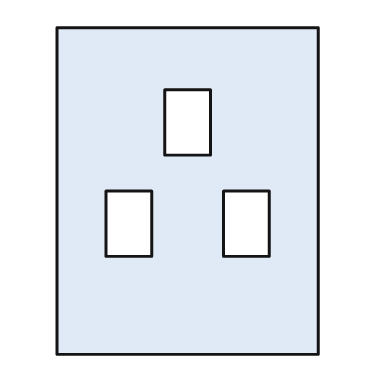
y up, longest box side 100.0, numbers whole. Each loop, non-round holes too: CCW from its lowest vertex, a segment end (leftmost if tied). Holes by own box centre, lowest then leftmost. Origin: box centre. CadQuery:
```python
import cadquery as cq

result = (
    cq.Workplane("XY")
    .moveTo(-40.0, -50.0)
    .lineTo(40.0, -50.0)
    .lineTo(40.0, 50.0)
    .lineTo(-40.0, 50.0)
    .close()
    .moveTo(-25.0, -20.0)
    .lineTo(-11.0, -20.0)
    .lineTo(-11.0, 0.0)
    .lineTo(-25.0, 0.0)
    .close()
    .moveTo(11.0, -20.0)
    .lineTo(25.0, -20.0)
    .lineTo(25.0, 0.0)
    .lineTo(11.0, 0.0)
    .close()
    .moveTo(-7.0, 11.0)
    .lineTo(7.0, 11.0)
    .lineTo(7.0, 31.0)
    .lineTo(-7.0, 31.0)
    .close()
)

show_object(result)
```